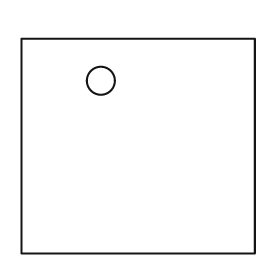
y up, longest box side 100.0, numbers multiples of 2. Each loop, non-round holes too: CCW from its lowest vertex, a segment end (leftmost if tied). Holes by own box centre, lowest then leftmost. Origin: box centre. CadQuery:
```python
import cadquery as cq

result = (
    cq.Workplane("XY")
    .moveTo(-50.0, -46.0)
    .lineTo(50.0, -46.0)
    .lineTo(50.0, 46.0)
    .lineTo(-50.0, 46.0)
    .close()
    .moveTo(-16.0, 28.0)
    .circle(6.0)
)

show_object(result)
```